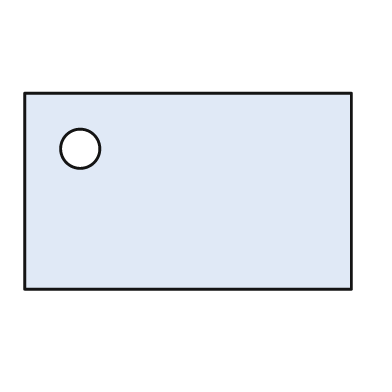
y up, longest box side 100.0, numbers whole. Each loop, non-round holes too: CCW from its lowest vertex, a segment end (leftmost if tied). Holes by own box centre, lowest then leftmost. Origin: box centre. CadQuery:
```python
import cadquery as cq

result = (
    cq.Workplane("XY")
    .moveTo(-50.0, -30.0)
    .lineTo(50.0, -30.0)
    .lineTo(50.0, 30.0)
    .lineTo(-50.0, 30.0)
    .close()
    .moveTo(-33.0, 13.0)
    .circle(6.0)
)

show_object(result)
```